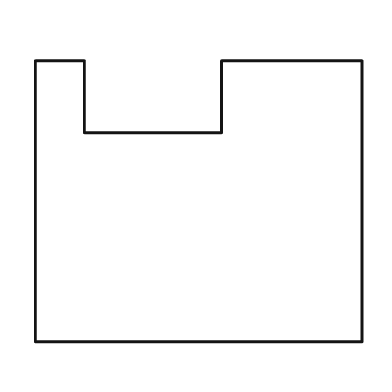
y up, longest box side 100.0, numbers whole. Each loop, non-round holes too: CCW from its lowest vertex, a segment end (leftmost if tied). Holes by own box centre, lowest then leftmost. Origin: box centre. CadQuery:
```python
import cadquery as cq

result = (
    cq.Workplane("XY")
    .moveTo(-50.0, -43.0)
    .lineTo(50.0, -43.0)
    .lineTo(50.0, 43.0)
    .lineTo(7.0, 43.0)
    .lineTo(7.0, 21.0)
    .lineTo(-35.0, 21.0)
    .lineTo(-35.0, 43.0)
    .lineTo(-50.0, 43.0)
    .close()
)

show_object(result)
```